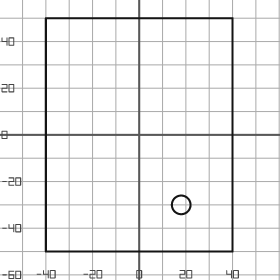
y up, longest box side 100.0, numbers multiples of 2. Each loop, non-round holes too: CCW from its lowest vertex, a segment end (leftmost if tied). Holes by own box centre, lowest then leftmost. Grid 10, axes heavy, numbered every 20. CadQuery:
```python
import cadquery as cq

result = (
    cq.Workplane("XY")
    .moveTo(-40.0, -50.0)
    .lineTo(40.0, -50.0)
    .lineTo(40.0, 50.0)
    .lineTo(-40.0, 50.0)
    .close()
    .moveTo(18.0, -30.0)
    .circle(4.0)
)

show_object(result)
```